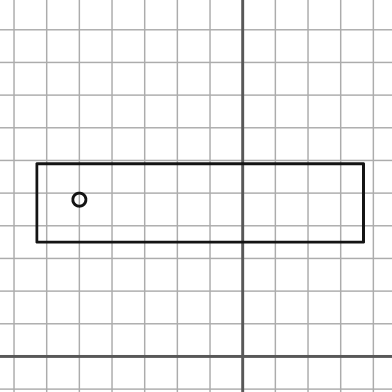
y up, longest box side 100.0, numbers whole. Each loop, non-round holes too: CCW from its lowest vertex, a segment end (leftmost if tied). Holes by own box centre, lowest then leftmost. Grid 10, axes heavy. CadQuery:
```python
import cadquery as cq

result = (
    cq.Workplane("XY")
    .moveTo(-63.0, 35.0)
    .lineTo(37.0, 35.0)
    .lineTo(37.0, 59.0)
    .lineTo(-63.0, 59.0)
    .close()
    .moveTo(-50.0, 48.0)
    .circle(2.0)
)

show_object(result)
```